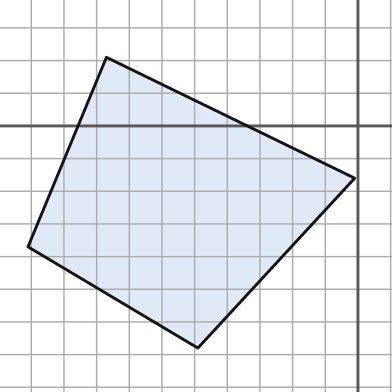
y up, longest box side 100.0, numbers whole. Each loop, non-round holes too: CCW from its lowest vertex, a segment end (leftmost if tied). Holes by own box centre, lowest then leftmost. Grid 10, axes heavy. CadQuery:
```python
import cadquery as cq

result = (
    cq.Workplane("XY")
    .moveTo(-49.0, -68.0)
    .lineTo(-1.0, -16.0)
    .lineTo(-77.0, 21.0)
    .lineTo(-101.0, -37.0)
    .close()
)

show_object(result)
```